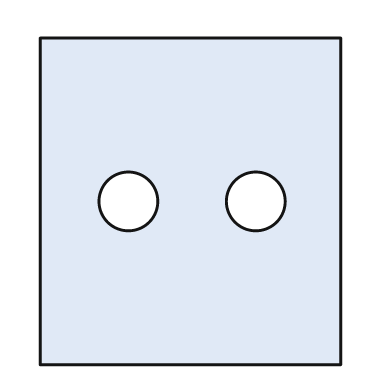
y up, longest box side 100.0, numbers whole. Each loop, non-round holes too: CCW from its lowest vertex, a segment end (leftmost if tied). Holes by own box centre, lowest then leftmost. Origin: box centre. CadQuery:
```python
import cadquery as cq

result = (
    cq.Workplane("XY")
    .moveTo(-46.0, -50.0)
    .lineTo(46.0, -50.0)
    .lineTo(46.0, 50.0)
    .lineTo(-46.0, 50.0)
    .close()
    .moveTo(-19.0, 0.0)
    .circle(9.0)
    .moveTo(20.0, 0.0)
    .circle(9.0)
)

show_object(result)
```